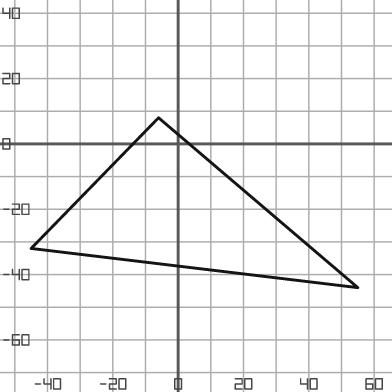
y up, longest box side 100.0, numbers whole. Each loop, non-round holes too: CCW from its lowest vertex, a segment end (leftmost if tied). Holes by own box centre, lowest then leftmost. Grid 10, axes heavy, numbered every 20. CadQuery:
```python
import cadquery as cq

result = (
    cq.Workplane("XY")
    .moveTo(55.0, -44.0)
    .lineTo(-6.0, 8.0)
    .lineTo(-45.0, -32.0)
    .close()
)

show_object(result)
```